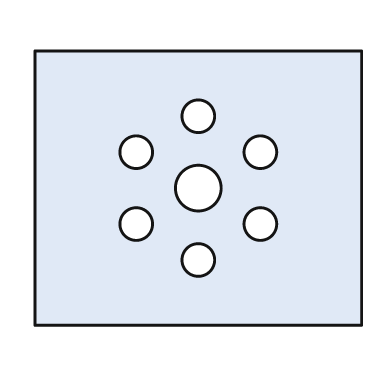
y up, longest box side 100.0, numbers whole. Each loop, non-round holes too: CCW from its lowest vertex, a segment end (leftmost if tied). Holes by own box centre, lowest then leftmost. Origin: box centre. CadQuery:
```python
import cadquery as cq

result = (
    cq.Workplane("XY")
    .moveTo(-50.0, -42.0)
    .lineTo(50.0, -42.0)
    .lineTo(50.0, 42.0)
    .lineTo(-50.0, 42.0)
    .close()
    .moveTo(0.0, -22.0)
    .circle(5.0)
    .moveTo(-19.0, -11.0)
    .circle(5.0)
    .moveTo(19.0, -11.0)
    .circle(5.0)
    .moveTo(0.0, 0.0)
    .circle(7.0)
    .moveTo(-19.0, 11.0)
    .circle(5.0)
    .moveTo(19.0, 11.0)
    .circle(5.0)
    .moveTo(0.0, 22.0)
    .circle(5.0)
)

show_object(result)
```